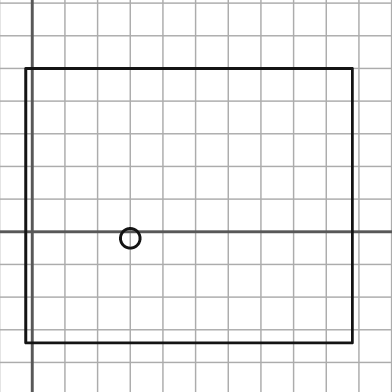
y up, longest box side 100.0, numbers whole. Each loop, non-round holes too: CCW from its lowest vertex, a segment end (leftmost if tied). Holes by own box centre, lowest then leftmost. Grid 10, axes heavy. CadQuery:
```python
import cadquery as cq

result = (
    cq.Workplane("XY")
    .moveTo(-2.0, -34.0)
    .lineTo(98.0, -34.0)
    .lineTo(98.0, 50.0)
    .lineTo(-2.0, 50.0)
    .close()
    .moveTo(30.0, -2.0)
    .circle(3.0)
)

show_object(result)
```